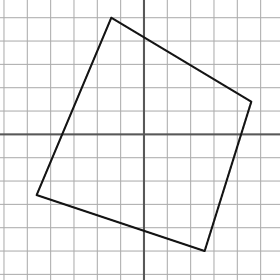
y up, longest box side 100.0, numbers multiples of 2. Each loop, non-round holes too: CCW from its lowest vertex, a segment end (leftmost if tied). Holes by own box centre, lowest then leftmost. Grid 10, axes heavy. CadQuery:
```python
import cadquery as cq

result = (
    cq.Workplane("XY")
    .moveTo(26.0, -50.0)
    .lineTo(46.0, 14.0)
    .lineTo(-14.0, 50.0)
    .lineTo(-46.0, -26.0)
    .close()
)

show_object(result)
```